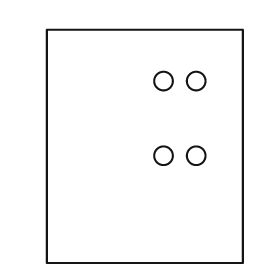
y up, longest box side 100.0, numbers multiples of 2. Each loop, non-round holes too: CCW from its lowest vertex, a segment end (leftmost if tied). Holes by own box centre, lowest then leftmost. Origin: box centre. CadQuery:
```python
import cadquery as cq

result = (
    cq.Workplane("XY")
    .moveTo(-42.0, -50.0)
    .lineTo(42.0, -50.0)
    .lineTo(42.0, 50.0)
    .lineTo(-42.0, 50.0)
    .close()
    .moveTo(8.0, -4.0)
    .circle(4.0)
    .moveTo(22.0, -4.0)
    .circle(4.0)
    .moveTo(8.0, 28.0)
    .circle(4.0)
    .moveTo(22.0, 28.0)
    .circle(4.0)
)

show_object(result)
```